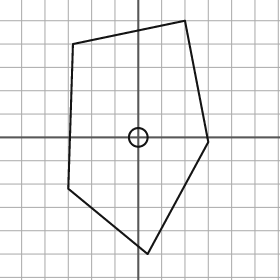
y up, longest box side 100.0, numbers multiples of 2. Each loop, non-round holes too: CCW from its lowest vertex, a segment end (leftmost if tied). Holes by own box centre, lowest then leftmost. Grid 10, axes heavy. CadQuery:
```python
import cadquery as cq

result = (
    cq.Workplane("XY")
    .moveTo(4.0, -50.0)
    .lineTo(30.0, -2.0)
    .lineTo(20.0, 50.0)
    .lineTo(-28.0, 40.0)
    .lineTo(-30.0, -22.0)
    .close()
    .moveTo(0.0, 0.0)
    .circle(4.0)
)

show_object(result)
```